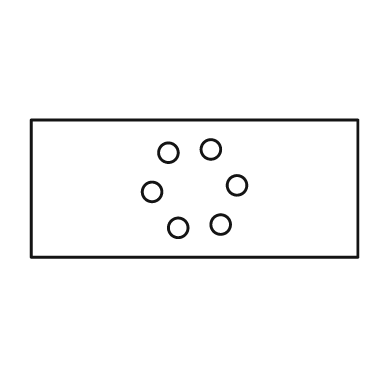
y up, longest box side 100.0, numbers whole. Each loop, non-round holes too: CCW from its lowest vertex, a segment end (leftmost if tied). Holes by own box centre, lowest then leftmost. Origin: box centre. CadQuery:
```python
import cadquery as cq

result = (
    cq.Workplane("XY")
    .moveTo(-50.0, -21.0)
    .lineTo(50.0, -21.0)
    .lineTo(50.0, 21.0)
    .lineTo(-50.0, 21.0)
    .close()
    .moveTo(-5.0, -12.0)
    .circle(3.0)
    .moveTo(8.0, -11.0)
    .circle(3.0)
    .moveTo(-13.0, -1.0)
    .circle(3.0)
    .moveTo(13.0, 1.0)
    .circle(3.0)
    .moveTo(-8.0, 11.0)
    .circle(3.0)
    .moveTo(5.0, 12.0)
    .circle(3.0)
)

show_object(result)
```